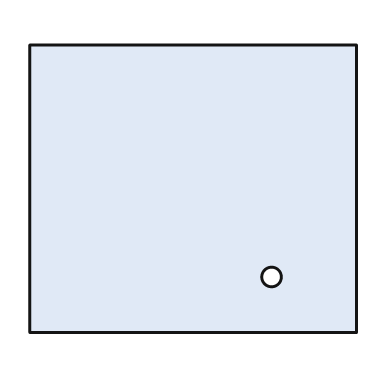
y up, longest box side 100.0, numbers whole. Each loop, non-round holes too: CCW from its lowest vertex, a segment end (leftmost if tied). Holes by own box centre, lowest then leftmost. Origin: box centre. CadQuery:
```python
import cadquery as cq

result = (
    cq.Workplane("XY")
    .moveTo(-50.0, -44.0)
    .lineTo(50.0, -44.0)
    .lineTo(50.0, 44.0)
    .lineTo(-50.0, 44.0)
    .close()
    .moveTo(24.0, -27.0)
    .circle(3.0)
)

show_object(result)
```